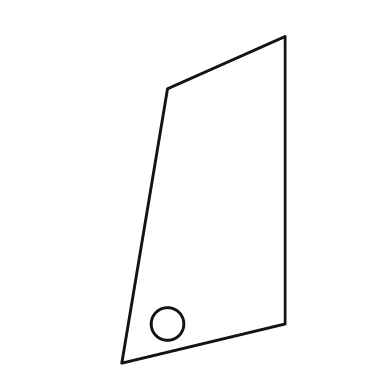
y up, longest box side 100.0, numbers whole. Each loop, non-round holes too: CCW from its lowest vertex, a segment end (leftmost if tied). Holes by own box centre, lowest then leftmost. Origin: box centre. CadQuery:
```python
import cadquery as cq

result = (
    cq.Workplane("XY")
    .moveTo(-25.0, -50.0)
    .lineTo(25.0, -38.0)
    .lineTo(25.0, 50.0)
    .lineTo(-11.0, 34.0)
    .close()
    .moveTo(-11.0, -38.0)
    .circle(5.0)
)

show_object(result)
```